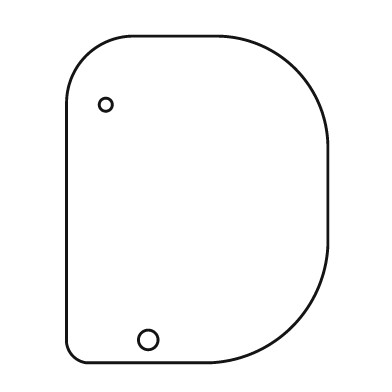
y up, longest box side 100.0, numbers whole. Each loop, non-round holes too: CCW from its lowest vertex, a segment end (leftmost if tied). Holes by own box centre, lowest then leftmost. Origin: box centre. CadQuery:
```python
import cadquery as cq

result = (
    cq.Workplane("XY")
    .moveTo(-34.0, -50.0)
    .lineTo(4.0, -50.0)
    .threePointArc((29.0, -39.0), (40.0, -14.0))
    .lineTo(40.0, 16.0)
    .threePointArc((30.0, 40.0), (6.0, 50.0))
    .lineTo(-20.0, 50.0)
    .threePointArc((-34.0, 44.0), (-40.0, 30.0))
    .lineTo(-40.0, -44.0)
    .threePointArc((-38.0, -48.0), (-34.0, -50.0))
    .close()
    .moveTo(-15.0, -43.0)
    .circle(3.0)
    .moveTo(-28.0, 29.0)
    .circle(2.0)
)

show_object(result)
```